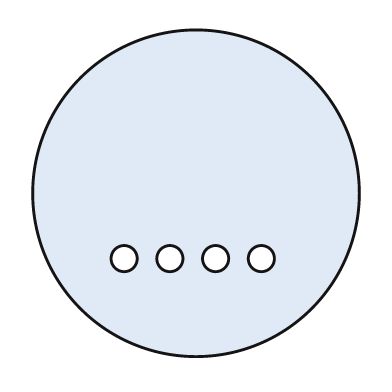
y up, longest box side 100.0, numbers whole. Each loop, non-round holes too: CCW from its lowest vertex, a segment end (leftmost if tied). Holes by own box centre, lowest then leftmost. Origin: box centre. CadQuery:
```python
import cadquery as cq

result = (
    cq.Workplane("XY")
    .moveTo(0.0, 0.0)
    .circle(50.0)
    .moveTo(-22.0, -20.0)
    .circle(4.0)
    .moveTo(-8.0, -20.0)
    .circle(4.0)
    .moveTo(6.0, -20.0)
    .circle(4.0)
    .moveTo(20.0, -20.0)
    .circle(4.0)
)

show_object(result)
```